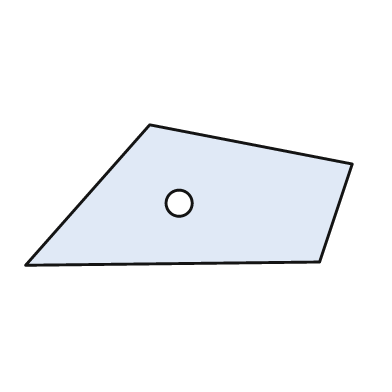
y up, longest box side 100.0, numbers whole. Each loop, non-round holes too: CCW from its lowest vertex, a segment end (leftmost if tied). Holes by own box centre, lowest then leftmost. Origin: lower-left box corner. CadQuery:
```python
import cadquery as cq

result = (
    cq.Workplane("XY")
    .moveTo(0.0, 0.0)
    .lineTo(90.0, 1.0)
    .lineTo(100.0, 31.0)
    .lineTo(38.0, 43.0)
    .close()
    .moveTo(47.0, 19.0)
    .circle(4.0)
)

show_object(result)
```